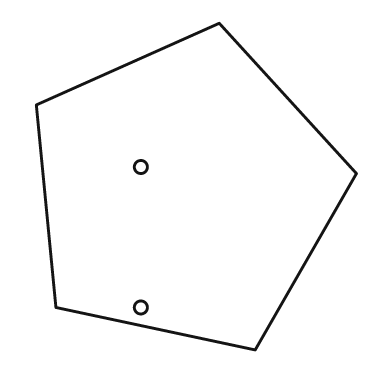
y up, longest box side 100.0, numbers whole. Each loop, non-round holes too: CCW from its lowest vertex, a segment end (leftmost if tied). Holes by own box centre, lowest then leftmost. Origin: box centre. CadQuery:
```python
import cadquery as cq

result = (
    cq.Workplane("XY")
    .moveTo(18.0, -50.0)
    .lineTo(49.0, 4.0)
    .lineTo(7.0, 50.0)
    .lineTo(-49.0, 25.0)
    .lineTo(-43.0, -37.0)
    .close()
    .moveTo(-17.0, -37.0)
    .circle(2.0)
    .moveTo(-17.0, 6.0)
    .circle(2.0)
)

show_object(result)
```